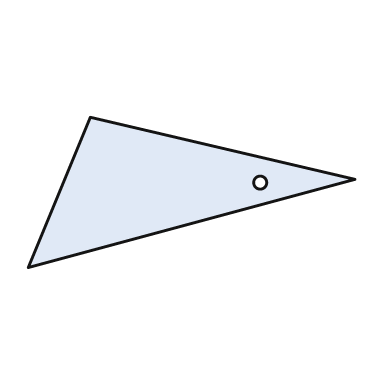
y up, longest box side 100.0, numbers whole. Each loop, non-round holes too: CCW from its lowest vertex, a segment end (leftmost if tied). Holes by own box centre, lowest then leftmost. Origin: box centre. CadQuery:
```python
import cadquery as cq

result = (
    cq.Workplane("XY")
    .moveTo(-50.0, -23.0)
    .lineTo(50.0, 4.0)
    .lineTo(-31.0, 23.0)
    .close()
    .moveTo(21.0, 3.0)
    .circle(2.0)
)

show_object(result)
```